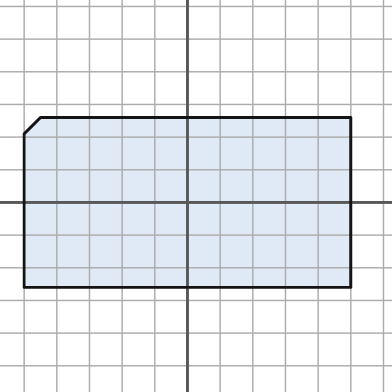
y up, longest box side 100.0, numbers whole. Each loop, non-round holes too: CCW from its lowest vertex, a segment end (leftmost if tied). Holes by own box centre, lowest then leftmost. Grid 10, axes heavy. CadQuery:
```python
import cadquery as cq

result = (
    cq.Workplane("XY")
    .moveTo(-50.0, -26.0)
    .lineTo(50.0, -26.0)
    .lineTo(50.0, 26.0)
    .lineTo(-45.0, 26.0)
    .lineTo(-50.0, 21.0)
    .close()
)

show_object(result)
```